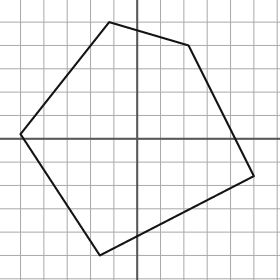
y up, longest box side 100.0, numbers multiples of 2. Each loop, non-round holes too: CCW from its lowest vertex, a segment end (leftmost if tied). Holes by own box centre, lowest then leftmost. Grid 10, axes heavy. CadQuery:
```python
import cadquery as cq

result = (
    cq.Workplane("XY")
    .moveTo(-16.0, -50.0)
    .lineTo(50.0, -16.0)
    .lineTo(22.0, 40.0)
    .lineTo(-12.0, 50.0)
    .lineTo(-50.0, 2.0)
    .close()
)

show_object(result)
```